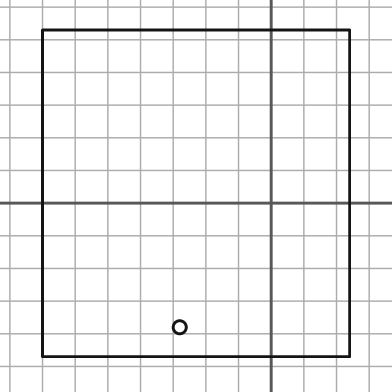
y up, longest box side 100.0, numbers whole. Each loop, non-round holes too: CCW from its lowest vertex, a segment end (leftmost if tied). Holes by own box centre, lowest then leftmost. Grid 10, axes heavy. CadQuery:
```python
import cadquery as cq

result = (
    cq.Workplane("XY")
    .moveTo(-70.0, -47.0)
    .lineTo(24.0, -47.0)
    .lineTo(24.0, 53.0)
    .lineTo(-70.0, 53.0)
    .close()
    .moveTo(-28.0, -38.0)
    .circle(2.0)
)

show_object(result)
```